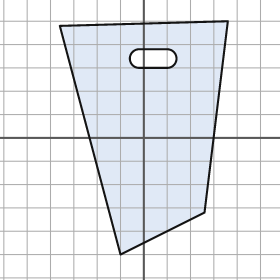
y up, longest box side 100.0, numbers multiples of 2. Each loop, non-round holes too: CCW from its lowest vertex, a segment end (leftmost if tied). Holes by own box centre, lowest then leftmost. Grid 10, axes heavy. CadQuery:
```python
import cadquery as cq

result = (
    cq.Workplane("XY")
    .moveTo(-10.0, -50.0)
    .lineTo(26.0, -32.0)
    .lineTo(36.0, 50.0)
    .lineTo(-36.0, 48.0)
    .close()
    .moveTo(-2.0, 30.0)
    .lineTo(10.0, 30.0)
    .threePointArc((14.0, 34.0), (10.0, 38.0))
    .lineTo(-2.0, 38.0)
    .threePointArc((-6.0, 34.0), (-2.0, 30.0))
    .close()
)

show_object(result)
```